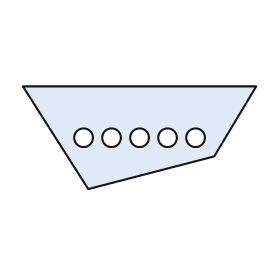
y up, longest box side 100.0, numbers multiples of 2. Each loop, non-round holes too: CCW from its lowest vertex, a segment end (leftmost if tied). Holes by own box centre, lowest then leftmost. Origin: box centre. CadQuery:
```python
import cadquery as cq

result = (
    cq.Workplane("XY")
    .moveTo(-22.0, -22.0)
    .lineTo(32.0, -8.0)
    .lineTo(50.0, 22.0)
    .lineTo(-50.0, 22.0)
    .close()
    .moveTo(-24.0, 0.0)
    .circle(4.0)
    .moveTo(-12.0, 0.0)
    .circle(4.0)
    .moveTo(0.0, 0.0)
    .circle(4.0)
    .moveTo(12.0, 0.0)
    .circle(4.0)
    .moveTo(24.0, 0.0)
    .circle(4.0)
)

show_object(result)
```